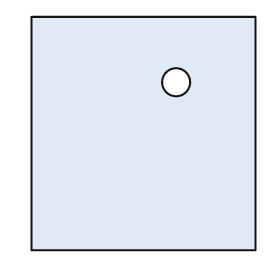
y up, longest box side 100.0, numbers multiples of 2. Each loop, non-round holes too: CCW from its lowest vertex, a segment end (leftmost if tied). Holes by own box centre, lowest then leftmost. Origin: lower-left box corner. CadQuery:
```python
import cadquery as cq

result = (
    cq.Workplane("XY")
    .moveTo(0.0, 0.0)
    .lineTo(96.0, 0.0)
    .lineTo(96.0, 100.0)
    .lineTo(0.0, 100.0)
    .close()
    .moveTo(62.0, 72.0)
    .circle(6.0)
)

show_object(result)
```